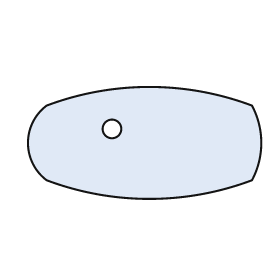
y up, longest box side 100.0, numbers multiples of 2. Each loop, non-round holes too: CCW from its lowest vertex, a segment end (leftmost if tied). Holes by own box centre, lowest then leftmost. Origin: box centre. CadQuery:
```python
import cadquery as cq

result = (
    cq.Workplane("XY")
    .moveTo(-42.0, -16.0)
    .threePointArc((2.0, -24.0), (46.0, -16.0))
    .threePointArc((50.0, 0.0), (46.0, 16.0))
    .threePointArc((2.0, 24.0), (-42.0, 16.0))
    .threePointArc((-50.0, 0.0), (-42.0, -16.0))
    .close()
    .moveTo(-14.0, 6.0)
    .circle(4.0)
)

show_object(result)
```